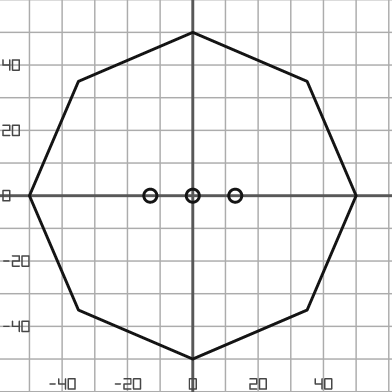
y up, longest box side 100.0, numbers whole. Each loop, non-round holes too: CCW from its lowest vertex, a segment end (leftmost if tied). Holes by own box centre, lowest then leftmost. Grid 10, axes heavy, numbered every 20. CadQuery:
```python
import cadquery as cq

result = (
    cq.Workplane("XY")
    .moveTo(0.0, -50.0)
    .lineTo(35.0, -35.0)
    .lineTo(50.0, 0.0)
    .lineTo(35.0, 35.0)
    .lineTo(0.0, 50.0)
    .lineTo(-35.0, 35.0)
    .lineTo(-50.0, 0.0)
    .lineTo(-35.0, -35.0)
    .close()
    .moveTo(-13.0, 0.0)
    .circle(2.0)
    .moveTo(0.0, 0.0)
    .circle(2.0)
    .moveTo(13.0, 0.0)
    .circle(2.0)
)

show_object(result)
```